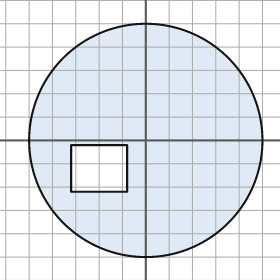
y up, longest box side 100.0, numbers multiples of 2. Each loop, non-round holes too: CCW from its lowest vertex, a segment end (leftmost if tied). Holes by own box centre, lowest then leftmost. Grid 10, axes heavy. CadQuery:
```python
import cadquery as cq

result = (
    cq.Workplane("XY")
    .moveTo(0.0, 0.0)
    .circle(50.0)
    .moveTo(-32.0, -22.0)
    .lineTo(-8.0, -22.0)
    .lineTo(-8.0, -2.0)
    .lineTo(-32.0, -2.0)
    .close()
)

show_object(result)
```